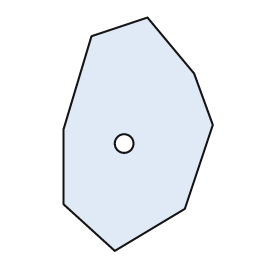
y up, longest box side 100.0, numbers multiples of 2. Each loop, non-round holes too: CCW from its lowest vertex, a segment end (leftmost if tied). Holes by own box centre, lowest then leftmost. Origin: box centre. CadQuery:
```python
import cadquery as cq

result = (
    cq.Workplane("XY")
    .moveTo(-10.0, -50.0)
    .lineTo(20.0, -32.0)
    .lineTo(32.0, 4.0)
    .lineTo(24.0, 26.0)
    .lineTo(4.0, 50.0)
    .lineTo(-20.0, 42.0)
    .lineTo(-32.0, 2.0)
    .lineTo(-32.0, -30.0)
    .close()
    .moveTo(-6.0, -4.0)
    .circle(4.0)
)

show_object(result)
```